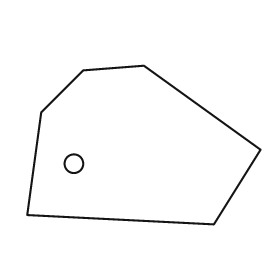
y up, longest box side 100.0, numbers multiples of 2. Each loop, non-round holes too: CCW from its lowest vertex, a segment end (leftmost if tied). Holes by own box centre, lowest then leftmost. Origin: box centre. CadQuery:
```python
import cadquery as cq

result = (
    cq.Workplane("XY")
    .moveTo(30.0, -34.0)
    .lineTo(50.0, -2.0)
    .lineTo(0.0, 34.0)
    .lineTo(-26.0, 32.0)
    .lineTo(-44.0, 14.0)
    .lineTo(-50.0, -30.0)
    .close()
    .moveTo(-30.0, -8.0)
    .circle(4.0)
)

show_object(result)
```